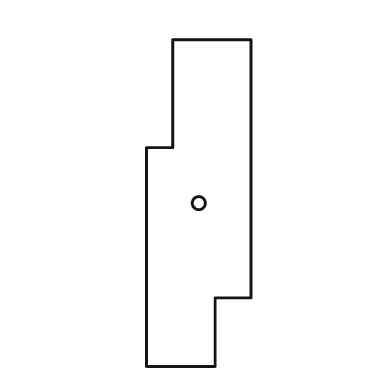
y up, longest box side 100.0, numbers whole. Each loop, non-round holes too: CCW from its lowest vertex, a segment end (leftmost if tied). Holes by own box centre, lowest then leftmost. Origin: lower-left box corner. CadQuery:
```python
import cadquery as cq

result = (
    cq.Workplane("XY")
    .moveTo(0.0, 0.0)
    .lineTo(21.0, 0.0)
    .lineTo(21.0, 21.0)
    .lineTo(32.0, 21.0)
    .lineTo(32.0, 100.0)
    .lineTo(8.0, 100.0)
    .lineTo(8.0, 67.0)
    .lineTo(0.0, 67.0)
    .close()
    .moveTo(16.0, 50.0)
    .circle(2.0)
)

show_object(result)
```